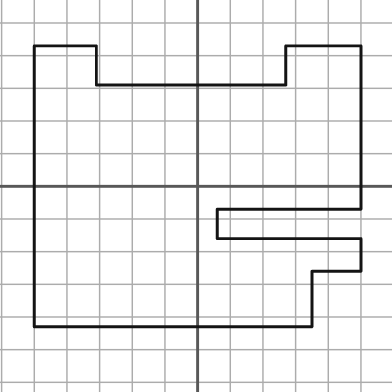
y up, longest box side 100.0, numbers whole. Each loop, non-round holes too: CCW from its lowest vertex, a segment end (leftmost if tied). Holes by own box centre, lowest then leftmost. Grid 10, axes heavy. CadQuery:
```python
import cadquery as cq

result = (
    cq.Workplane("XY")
    .moveTo(-50.0, -43.0)
    .lineTo(35.0, -43.0)
    .lineTo(35.0, -26.0)
    .lineTo(50.0, -26.0)
    .lineTo(50.0, -16.0)
    .lineTo(6.0, -16.0)
    .lineTo(6.0, -7.0)
    .lineTo(50.0, -7.0)
    .lineTo(50.0, 43.0)
    .lineTo(27.0, 43.0)
    .lineTo(27.0, 31.0)
    .lineTo(-31.0, 31.0)
    .lineTo(-31.0, 43.0)
    .lineTo(-50.0, 43.0)
    .close()
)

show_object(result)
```